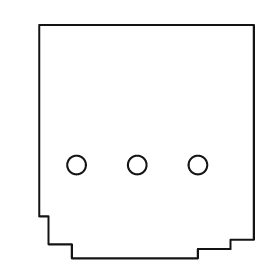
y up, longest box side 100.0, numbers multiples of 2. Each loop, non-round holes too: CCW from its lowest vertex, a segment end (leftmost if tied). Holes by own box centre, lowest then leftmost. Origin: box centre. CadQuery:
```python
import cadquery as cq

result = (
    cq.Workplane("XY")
    .moveTo(-32.0, -50.0)
    .lineTo(22.0, -50.0)
    .lineTo(22.0, -46.0)
    .lineTo(36.0, -46.0)
    .lineTo(36.0, -42.0)
    .lineTo(46.0, -42.0)
    .lineTo(46.0, 50.0)
    .lineTo(-46.0, 50.0)
    .lineTo(-46.0, -32.0)
    .lineTo(-42.0, -32.0)
    .lineTo(-42.0, -44.0)
    .lineTo(-32.0, -44.0)
    .close()
    .moveTo(-30.0, -10.0)
    .circle(4.0)
    .moveTo(-4.0, -10.0)
    .circle(4.0)
    .moveTo(22.0, -10.0)
    .circle(4.0)
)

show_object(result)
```